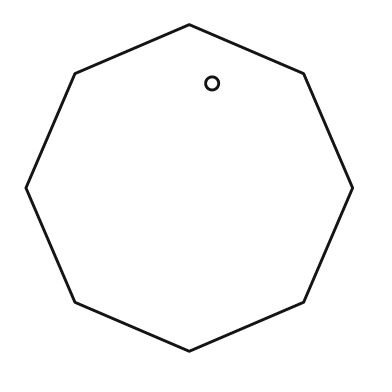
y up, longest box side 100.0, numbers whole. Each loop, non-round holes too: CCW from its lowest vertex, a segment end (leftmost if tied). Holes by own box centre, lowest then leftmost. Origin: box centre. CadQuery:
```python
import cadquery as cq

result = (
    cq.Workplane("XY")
    .moveTo(0.0, -50.0)
    .lineTo(35.0, -35.0)
    .lineTo(50.0, 0.0)
    .lineTo(35.0, 35.0)
    .lineTo(0.0, 50.0)
    .lineTo(-35.0, 35.0)
    .lineTo(-50.0, 0.0)
    .lineTo(-35.0, -35.0)
    .close()
    .moveTo(7.0, 32.0)
    .circle(2.0)
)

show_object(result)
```